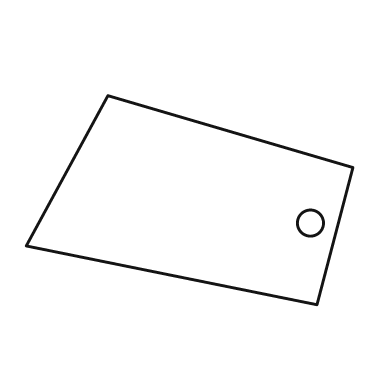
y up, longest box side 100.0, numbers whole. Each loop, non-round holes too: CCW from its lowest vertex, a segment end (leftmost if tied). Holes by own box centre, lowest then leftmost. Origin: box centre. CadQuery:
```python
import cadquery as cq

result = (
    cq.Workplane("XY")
    .moveTo(39.0, -32.0)
    .lineTo(50.0, 10.0)
    .lineTo(-25.0, 32.0)
    .lineTo(-50.0, -14.0)
    .close()
    .moveTo(37.0, -7.0)
    .circle(4.0)
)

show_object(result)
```